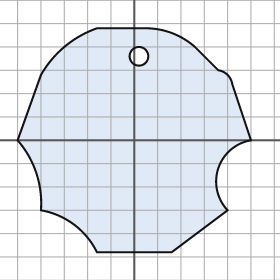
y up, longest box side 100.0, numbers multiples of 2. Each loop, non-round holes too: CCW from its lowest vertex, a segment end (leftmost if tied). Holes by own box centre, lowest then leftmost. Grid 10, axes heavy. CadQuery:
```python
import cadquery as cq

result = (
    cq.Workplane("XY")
    .moveTo(-16.0, -48.0)
    .lineTo(16.0, -48.0)
    .lineTo(40.0, -30.0)
    .threePointArc((36.0, -12.0), (50.0, 0.0))
    .lineTo(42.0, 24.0)
    .threePointArc((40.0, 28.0), (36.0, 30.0))
    .lineTo(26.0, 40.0)
    .threePointArc((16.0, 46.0), (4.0, 48.0))
    .lineTo(-16.0, 48.0)
    .threePointArc((-30.0, 40.0), (-40.0, 28.0))
    .lineTo(-50.0, 0.0)
    .threePointArc((-42.0, -14.0), (-40.0, -30.0))
    .threePointArc((-26.0, -36.0), (-16.0, -48.0))
    .close()
    .moveTo(2.0, 36.0)
    .circle(4.0)
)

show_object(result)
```